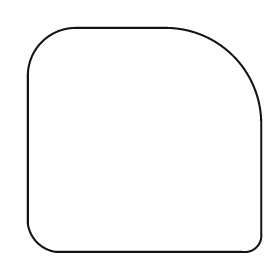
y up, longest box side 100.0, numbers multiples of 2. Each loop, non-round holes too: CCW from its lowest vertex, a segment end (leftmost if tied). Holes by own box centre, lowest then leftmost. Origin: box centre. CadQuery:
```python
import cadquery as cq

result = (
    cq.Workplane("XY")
    .moveTo(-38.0, -48.0)
    .lineTo(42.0, -48.0)
    .threePointArc((48.0, -46.0), (50.0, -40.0))
    .lineTo(50.0, 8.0)
    .threePointArc((38.0, 36.0), (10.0, 48.0))
    .lineTo(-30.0, 48.0)
    .threePointArc((-44.0, 42.0), (-50.0, 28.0))
    .lineTo(-50.0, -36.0)
    .threePointArc((-46.0, -44.0), (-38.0, -48.0))
    .close()
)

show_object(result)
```